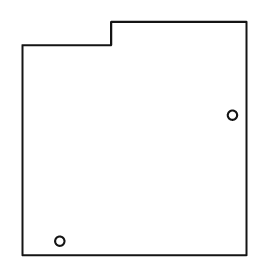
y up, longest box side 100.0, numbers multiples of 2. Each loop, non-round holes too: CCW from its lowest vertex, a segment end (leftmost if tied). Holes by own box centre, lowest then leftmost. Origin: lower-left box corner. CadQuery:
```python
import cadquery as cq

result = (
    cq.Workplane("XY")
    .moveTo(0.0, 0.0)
    .lineTo(96.0, 0.0)
    .lineTo(96.0, 100.0)
    .lineTo(38.0, 100.0)
    .lineTo(38.0, 90.0)
    .lineTo(0.0, 90.0)
    .close()
    .moveTo(16.0, 6.0)
    .circle(2.0)
    .moveTo(90.0, 60.0)
    .circle(2.0)
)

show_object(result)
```